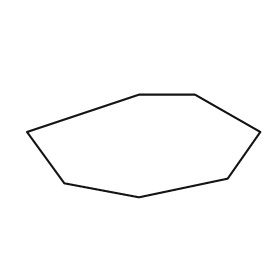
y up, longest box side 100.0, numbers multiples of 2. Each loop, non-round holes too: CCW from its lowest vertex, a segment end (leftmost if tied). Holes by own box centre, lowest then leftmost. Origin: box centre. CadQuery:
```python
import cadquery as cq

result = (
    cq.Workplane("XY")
    .moveTo(-2.0, -22.0)
    .lineTo(36.0, -14.0)
    .lineTo(50.0, 6.0)
    .lineTo(22.0, 22.0)
    .lineTo(-2.0, 22.0)
    .lineTo(-50.0, 6.0)
    .lineTo(-34.0, -16.0)
    .close()
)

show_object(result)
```